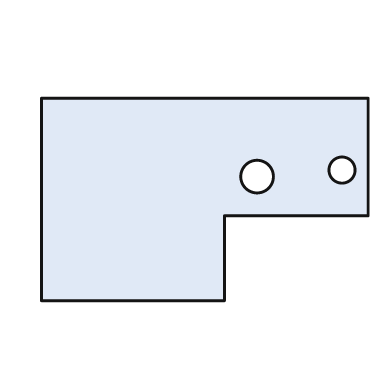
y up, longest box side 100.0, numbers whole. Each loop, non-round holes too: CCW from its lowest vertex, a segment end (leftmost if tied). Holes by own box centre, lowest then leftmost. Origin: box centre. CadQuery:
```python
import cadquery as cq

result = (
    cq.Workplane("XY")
    .moveTo(-50.0, -31.0)
    .lineTo(6.0, -31.0)
    .lineTo(6.0, -5.0)
    .lineTo(50.0, -5.0)
    .lineTo(50.0, 31.0)
    .lineTo(-50.0, 31.0)
    .close()
    .moveTo(16.0, 7.0)
    .circle(5.0)
    .moveTo(42.0, 9.0)
    .circle(4.0)
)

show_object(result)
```